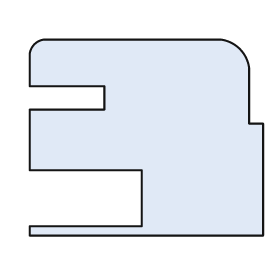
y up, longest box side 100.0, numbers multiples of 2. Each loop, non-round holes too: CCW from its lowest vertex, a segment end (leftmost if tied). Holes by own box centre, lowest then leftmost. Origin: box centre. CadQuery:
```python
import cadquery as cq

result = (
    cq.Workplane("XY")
    .moveTo(-50.0, -42.0)
    .lineTo(50.0, -42.0)
    .lineTo(50.0, 6.0)
    .lineTo(44.0, 6.0)
    .lineTo(44.0, 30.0)
    .threePointArc((40.0, 38.0), (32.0, 42.0))
    .lineTo(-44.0, 42.0)
    .threePointArc((-48.0, 40.0), (-50.0, 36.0))
    .lineTo(-50.0, 22.0)
    .lineTo(-18.0, 22.0)
    .lineTo(-18.0, 12.0)
    .lineTo(-50.0, 12.0)
    .lineTo(-50.0, -14.0)
    .lineTo(-2.0, -14.0)
    .lineTo(-2.0, -38.0)
    .lineTo(-50.0, -38.0)
    .close()
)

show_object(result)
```